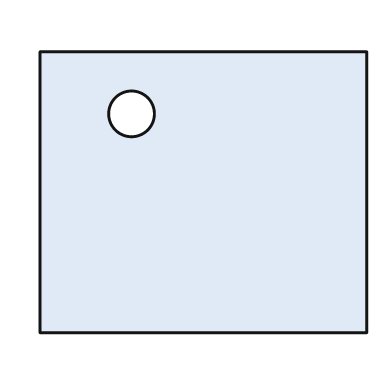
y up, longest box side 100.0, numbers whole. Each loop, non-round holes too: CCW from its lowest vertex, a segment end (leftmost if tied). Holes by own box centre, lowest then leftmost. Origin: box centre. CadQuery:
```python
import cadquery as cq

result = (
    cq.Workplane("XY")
    .moveTo(-50.0, -43.0)
    .lineTo(50.0, -43.0)
    .lineTo(50.0, 43.0)
    .lineTo(-50.0, 43.0)
    .close()
    .moveTo(-22.0, 24.0)
    .circle(7.0)
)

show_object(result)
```